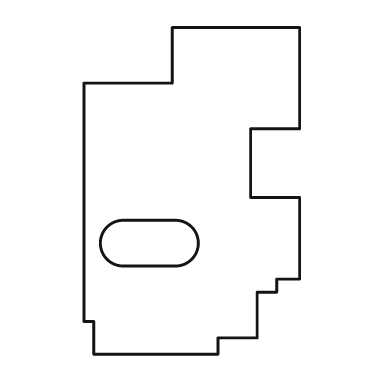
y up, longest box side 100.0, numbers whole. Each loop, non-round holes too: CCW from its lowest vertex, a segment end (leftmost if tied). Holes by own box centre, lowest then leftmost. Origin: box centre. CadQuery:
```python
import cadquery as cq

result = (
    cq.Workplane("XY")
    .moveTo(-30.0, -50.0)
    .lineTo(8.0, -50.0)
    .lineTo(8.0, -45.0)
    .lineTo(20.0, -45.0)
    .lineTo(20.0, -31.0)
    .lineTo(26.0, -31.0)
    .lineTo(26.0, -27.0)
    .lineTo(33.0, -27.0)
    .lineTo(33.0, -2.0)
    .lineTo(18.0, -2.0)
    .lineTo(18.0, 19.0)
    .lineTo(33.0, 19.0)
    .lineTo(33.0, 50.0)
    .lineTo(-6.0, 50.0)
    .lineTo(-6.0, 33.0)
    .lineTo(-33.0, 33.0)
    .lineTo(-33.0, -40.0)
    .lineTo(-30.0, -40.0)
    .close()
    .moveTo(-21.0, -23.0)
    .lineTo(-5.0, -23.0)
    .threePointArc((2.0, -16.0), (-5.0, -9.0))
    .lineTo(-21.0, -9.0)
    .threePointArc((-28.0, -16.0), (-21.0, -23.0))
    .close()
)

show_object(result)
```